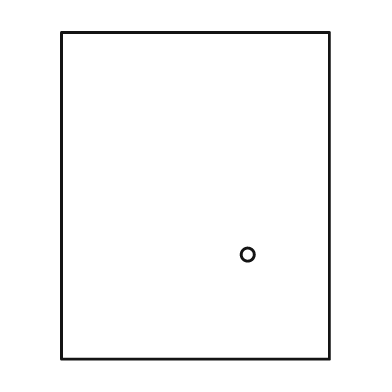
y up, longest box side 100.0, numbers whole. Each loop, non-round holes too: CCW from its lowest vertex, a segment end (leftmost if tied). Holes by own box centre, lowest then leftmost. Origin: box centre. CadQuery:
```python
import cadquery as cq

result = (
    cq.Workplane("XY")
    .moveTo(-41.0, -50.0)
    .lineTo(41.0, -50.0)
    .lineTo(41.0, 50.0)
    .lineTo(-41.0, 50.0)
    .close()
    .moveTo(16.0, -18.0)
    .circle(2.0)
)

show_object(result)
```